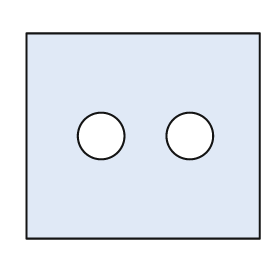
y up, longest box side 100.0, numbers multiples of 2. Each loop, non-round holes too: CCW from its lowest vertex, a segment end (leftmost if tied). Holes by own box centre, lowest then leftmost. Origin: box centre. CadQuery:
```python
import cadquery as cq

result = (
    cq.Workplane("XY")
    .moveTo(-50.0, -44.0)
    .lineTo(50.0, -44.0)
    .lineTo(50.0, 44.0)
    .lineTo(-50.0, 44.0)
    .close()
    .moveTo(-18.0, 0.0)
    .circle(10.0)
    .moveTo(20.0, 0.0)
    .circle(10.0)
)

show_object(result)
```